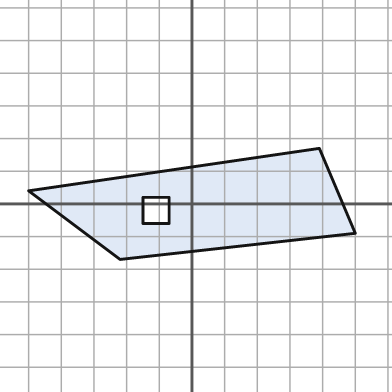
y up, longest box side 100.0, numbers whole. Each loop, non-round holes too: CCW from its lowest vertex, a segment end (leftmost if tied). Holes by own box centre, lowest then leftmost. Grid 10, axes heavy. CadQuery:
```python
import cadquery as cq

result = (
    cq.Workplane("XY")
    .moveTo(-22.0, -17.0)
    .lineTo(50.0, -9.0)
    .lineTo(39.0, 17.0)
    .lineTo(-50.0, 4.0)
    .close()
    .moveTo(-15.0, -6.0)
    .lineTo(-7.0, -6.0)
    .lineTo(-7.0, 2.0)
    .lineTo(-15.0, 2.0)
    .close()
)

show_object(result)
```